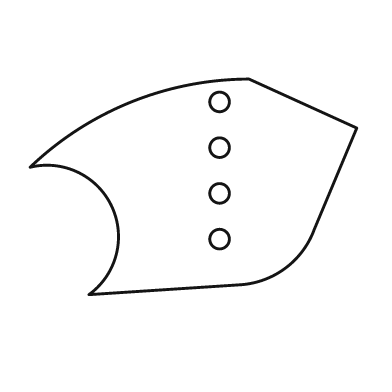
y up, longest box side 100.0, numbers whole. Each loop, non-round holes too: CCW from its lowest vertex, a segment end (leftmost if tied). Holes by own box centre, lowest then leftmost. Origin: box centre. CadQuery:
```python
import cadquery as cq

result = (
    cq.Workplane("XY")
    .moveTo(-32.0, -33.0)
    .lineTo(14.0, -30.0)
    .threePointArc((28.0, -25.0), (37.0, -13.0))
    .lineTo(50.0, 18.0)
    .lineTo(17.0, 33.0)
    .threePointArc((-19.0, 26.0), (-50.0, 6.0))
    .threePointArc((-25.0, -6.0), (-32.0, -33.0))
    .close()
    .moveTo(8.0, -16.0)
    .circle(3.0)
    .moveTo(8.0, -2.0)
    .circle(3.0)
    .moveTo(8.0, 12.0)
    .circle(3.0)
    .moveTo(8.0, 26.0)
    .circle(3.0)
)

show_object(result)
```